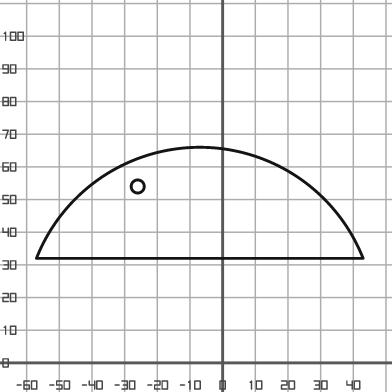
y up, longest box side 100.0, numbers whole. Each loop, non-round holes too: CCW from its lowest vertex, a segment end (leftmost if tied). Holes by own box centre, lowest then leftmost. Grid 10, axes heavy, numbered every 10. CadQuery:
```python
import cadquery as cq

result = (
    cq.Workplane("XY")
    .moveTo(-57.0, 32.0)
    .lineTo(43.0, 32.0)
    .threePointArc((-7.0, 66.0), (-57.0, 32.0))
    .close()
    .moveTo(-26.0, 54.0)
    .circle(2.0)
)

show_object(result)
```